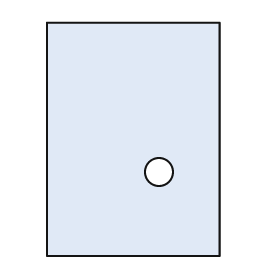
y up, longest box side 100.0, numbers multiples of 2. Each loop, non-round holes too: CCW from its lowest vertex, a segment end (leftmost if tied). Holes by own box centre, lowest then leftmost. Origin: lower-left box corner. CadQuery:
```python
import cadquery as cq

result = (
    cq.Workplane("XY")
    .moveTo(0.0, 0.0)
    .lineTo(74.0, 0.0)
    .lineTo(74.0, 100.0)
    .lineTo(0.0, 100.0)
    .close()
    .moveTo(48.0, 36.0)
    .circle(6.0)
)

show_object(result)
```